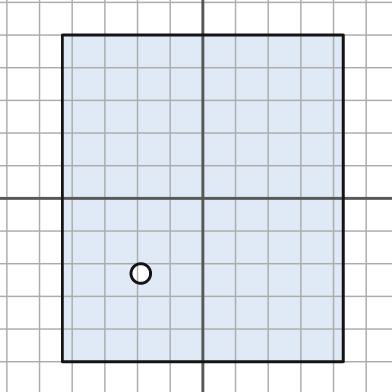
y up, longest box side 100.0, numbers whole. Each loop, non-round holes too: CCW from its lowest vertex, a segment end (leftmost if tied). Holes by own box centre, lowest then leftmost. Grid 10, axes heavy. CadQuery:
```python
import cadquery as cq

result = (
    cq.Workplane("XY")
    .moveTo(-43.0, -50.0)
    .lineTo(43.0, -50.0)
    .lineTo(43.0, 50.0)
    .lineTo(-43.0, 50.0)
    .close()
    .moveTo(-19.0, -23.0)
    .circle(3.0)
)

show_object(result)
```